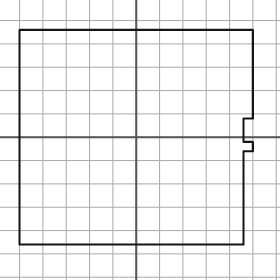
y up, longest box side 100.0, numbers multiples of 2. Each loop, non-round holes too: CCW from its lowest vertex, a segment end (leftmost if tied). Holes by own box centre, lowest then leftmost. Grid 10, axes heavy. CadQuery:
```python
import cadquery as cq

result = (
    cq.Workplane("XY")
    .moveTo(-50.0, -46.0)
    .lineTo(46.0, -46.0)
    .lineTo(46.0, -6.0)
    .lineTo(50.0, -6.0)
    .lineTo(50.0, -2.0)
    .lineTo(46.0, -2.0)
    .lineTo(46.0, 8.0)
    .lineTo(50.0, 8.0)
    .lineTo(50.0, 46.0)
    .lineTo(-50.0, 46.0)
    .close()
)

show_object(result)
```